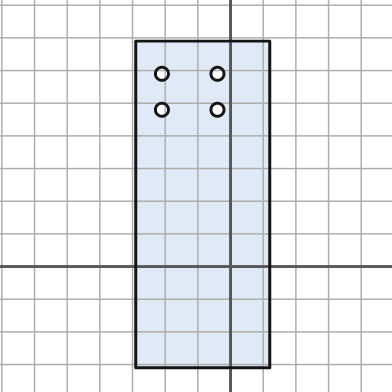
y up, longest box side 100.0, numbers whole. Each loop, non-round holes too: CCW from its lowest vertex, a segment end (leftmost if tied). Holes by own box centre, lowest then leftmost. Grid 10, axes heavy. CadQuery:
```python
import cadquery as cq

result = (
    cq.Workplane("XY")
    .moveTo(-29.0, -31.0)
    .lineTo(12.0, -31.0)
    .lineTo(12.0, 69.0)
    .lineTo(-29.0, 69.0)
    .close()
    .moveTo(-21.0, 48.0)
    .circle(2.0)
    .moveTo(-4.0, 48.0)
    .circle(2.0)
    .moveTo(-21.0, 59.0)
    .circle(2.0)
    .moveTo(-4.0, 59.0)
    .circle(2.0)
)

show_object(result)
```